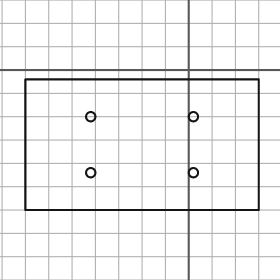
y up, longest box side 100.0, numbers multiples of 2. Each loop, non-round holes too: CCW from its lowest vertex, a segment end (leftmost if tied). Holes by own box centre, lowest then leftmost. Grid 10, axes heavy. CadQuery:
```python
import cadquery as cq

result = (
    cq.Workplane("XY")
    .moveTo(-70.0, -60.0)
    .lineTo(30.0, -60.0)
    .lineTo(30.0, -4.0)
    .lineTo(-70.0, -4.0)
    .close()
    .moveTo(-42.0, -44.0)
    .circle(2.0)
    .moveTo(2.0, -44.0)
    .circle(2.0)
    .moveTo(-42.0, -20.0)
    .circle(2.0)
    .moveTo(2.0, -20.0)
    .circle(2.0)
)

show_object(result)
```